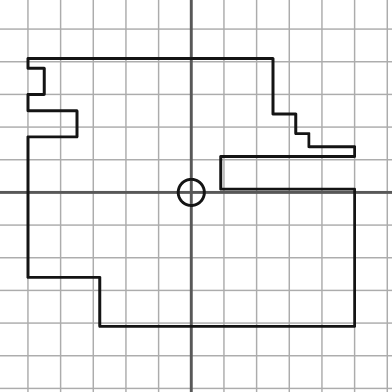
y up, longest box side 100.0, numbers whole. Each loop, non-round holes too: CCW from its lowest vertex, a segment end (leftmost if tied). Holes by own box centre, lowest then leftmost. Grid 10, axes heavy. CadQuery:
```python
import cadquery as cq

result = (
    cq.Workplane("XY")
    .moveTo(-28.0, -41.0)
    .lineTo(50.0, -41.0)
    .lineTo(50.0, 1.0)
    .lineTo(9.0, 1.0)
    .lineTo(9.0, 11.0)
    .lineTo(50.0, 11.0)
    .lineTo(50.0, 14.0)
    .lineTo(36.0, 14.0)
    .lineTo(36.0, 18.0)
    .lineTo(32.0, 18.0)
    .lineTo(32.0, 24.0)
    .lineTo(25.0, 24.0)
    .lineTo(25.0, 41.0)
    .lineTo(-50.0, 41.0)
    .lineTo(-50.0, 38.0)
    .lineTo(-45.0, 38.0)
    .lineTo(-45.0, 30.0)
    .lineTo(-50.0, 30.0)
    .lineTo(-50.0, 25.0)
    .lineTo(-35.0, 25.0)
    .lineTo(-35.0, 17.0)
    .lineTo(-50.0, 17.0)
    .lineTo(-50.0, -26.0)
    .lineTo(-28.0, -26.0)
    .close()
    .moveTo(0.0, 0.0)
    .circle(4.0)
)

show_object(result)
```